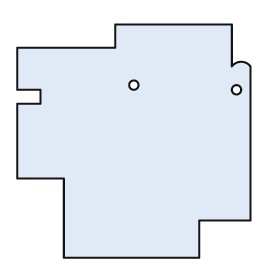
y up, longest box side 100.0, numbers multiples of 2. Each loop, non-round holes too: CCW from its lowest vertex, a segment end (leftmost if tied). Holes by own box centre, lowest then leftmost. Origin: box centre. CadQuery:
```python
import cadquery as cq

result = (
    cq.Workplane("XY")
    .moveTo(-30.0, -50.0)
    .lineTo(28.0, -50.0)
    .lineTo(28.0, -34.0)
    .lineTo(50.0, -34.0)
    .lineTo(50.0, 32.0)
    .threePointArc((46.0, 34.0), (42.0, 32.0))
    .lineTo(42.0, 50.0)
    .lineTo(-8.0, 50.0)
    .lineTo(-8.0, 40.0)
    .lineTo(-50.0, 40.0)
    .lineTo(-50.0, 22.0)
    .lineTo(-40.0, 22.0)
    .lineTo(-40.0, 16.0)
    .lineTo(-50.0, 16.0)
    .lineTo(-50.0, -16.0)
    .lineTo(-30.0, -16.0)
    .close()
    .moveTo(44.0, 22.0)
    .circle(2.0)
    .moveTo(0.0, 24.0)
    .circle(2.0)
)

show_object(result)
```